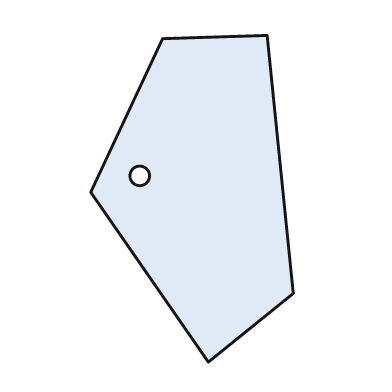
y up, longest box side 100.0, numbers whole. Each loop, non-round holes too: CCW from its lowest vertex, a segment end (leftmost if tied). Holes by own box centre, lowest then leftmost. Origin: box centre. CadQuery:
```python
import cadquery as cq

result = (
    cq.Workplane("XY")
    .moveTo(5.0, -50.0)
    .lineTo(31.0, -29.0)
    .lineTo(23.0, 50.0)
    .lineTo(-9.0, 49.0)
    .lineTo(-31.0, 2.0)
    .close()
    .moveTo(-16.0, 7.0)
    .circle(3.0)
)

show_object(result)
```